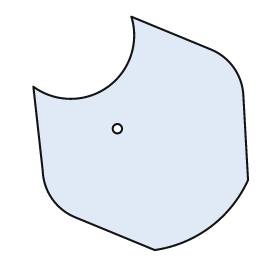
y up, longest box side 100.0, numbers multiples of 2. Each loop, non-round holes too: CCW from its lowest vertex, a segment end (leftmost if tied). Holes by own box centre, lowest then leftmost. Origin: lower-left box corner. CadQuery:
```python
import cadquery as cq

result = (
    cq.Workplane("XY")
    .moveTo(52.0, 0.0)
    .threePointArc((76.0, 10.0), (92.0, 30.0))
    .lineTo(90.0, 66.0)
    .threePointArc((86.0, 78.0), (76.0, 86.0))
    .lineTo(42.0, 100.0)
    .threePointArc((32.0, 70.0), (0.0, 70.0))
    .lineTo(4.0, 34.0)
    .threePointArc((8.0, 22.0), (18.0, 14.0))
    .close()
    .moveTo(36.0, 52.0)
    .circle(2.0)
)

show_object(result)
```